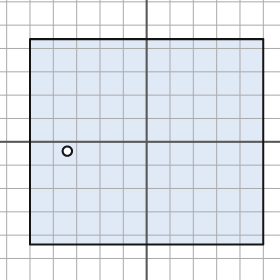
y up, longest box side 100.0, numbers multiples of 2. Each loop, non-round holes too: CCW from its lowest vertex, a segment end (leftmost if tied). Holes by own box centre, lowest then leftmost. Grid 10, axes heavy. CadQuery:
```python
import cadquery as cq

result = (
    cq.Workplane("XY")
    .moveTo(-50.0, -44.0)
    .lineTo(50.0, -44.0)
    .lineTo(50.0, 44.0)
    .lineTo(-50.0, 44.0)
    .close()
    .moveTo(-34.0, -4.0)
    .circle(2.0)
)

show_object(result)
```